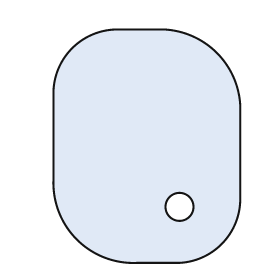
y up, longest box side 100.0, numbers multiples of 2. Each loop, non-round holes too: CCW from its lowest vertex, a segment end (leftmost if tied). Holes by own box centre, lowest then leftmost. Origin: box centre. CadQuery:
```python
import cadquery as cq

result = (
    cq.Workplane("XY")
    .moveTo(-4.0, -50.0)
    .lineTo(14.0, -50.0)
    .threePointArc((32.0, -42.0), (40.0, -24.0))
    .lineTo(40.0, 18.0)
    .threePointArc((30.0, 40.0), (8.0, 50.0))
    .lineTo(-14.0, 50.0)
    .threePointArc((-32.0, 42.0), (-40.0, 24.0))
    .lineTo(-40.0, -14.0)
    .threePointArc((-30.0, -40.0), (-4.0, -50.0))
    .close()
    .moveTo(14.0, -26.0)
    .circle(6.0)
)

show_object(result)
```